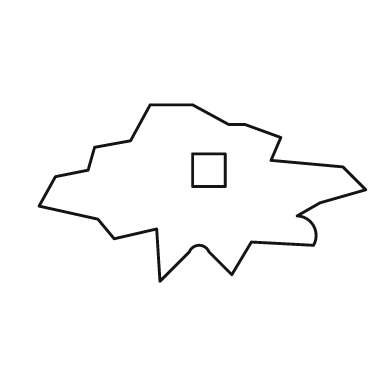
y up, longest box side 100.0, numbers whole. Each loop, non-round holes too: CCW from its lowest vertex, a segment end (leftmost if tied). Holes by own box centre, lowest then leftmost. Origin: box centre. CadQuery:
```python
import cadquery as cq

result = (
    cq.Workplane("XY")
    .moveTo(-13.0, -27.0)
    .lineTo(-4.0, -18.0)
    .threePointArc((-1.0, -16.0), (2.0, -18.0))
    .lineTo(9.0, -25.0)
    .lineTo(15.0, -15.0)
    .lineTo(34.0, -16.0)
    .threePointArc((34.0, -10.0), (29.0, -7.0))
    .lineTo(36.0, -3.0)
    .lineTo(50.0, 1.0)
    .lineTo(43.0, 8.0)
    .lineTo(21.0, 10.0)
    .lineTo(24.0, 17.0)
    .lineTo(13.0, 21.0)
    .lineTo(8.0, 21.0)
    .lineTo(-3.0, 27.0)
    .lineTo(-16.0, 27.0)
    .lineTo(-22.0, 16.0)
    .lineTo(-33.0, 14.0)
    .lineTo(-35.0, 7.0)
    .lineTo(-45.0, 5.0)
    .lineTo(-50.0, -4.0)
    .lineTo(-32.0, -8.0)
    .lineTo(-27.0, -14.0)
    .lineTo(-14.0, -11.0)
    .close()
    .moveTo(-3.0, 2.0)
    .lineTo(7.0, 2.0)
    .lineTo(7.0, 12.0)
    .lineTo(-3.0, 12.0)
    .close()
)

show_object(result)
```